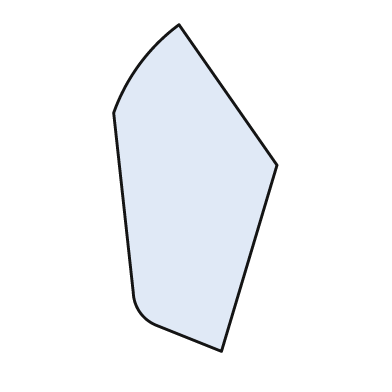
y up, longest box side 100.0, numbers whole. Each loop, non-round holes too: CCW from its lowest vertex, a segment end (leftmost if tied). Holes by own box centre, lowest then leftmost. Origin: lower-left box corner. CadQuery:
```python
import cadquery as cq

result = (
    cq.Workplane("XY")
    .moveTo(33.0, 0.0)
    .lineTo(50.0, 57.0)
    .lineTo(20.0, 100.0)
    .threePointArc((8.0, 88.0), (0.0, 73.0))
    .lineTo(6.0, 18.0)
    .threePointArc((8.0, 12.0), (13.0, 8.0))
    .close()
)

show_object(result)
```